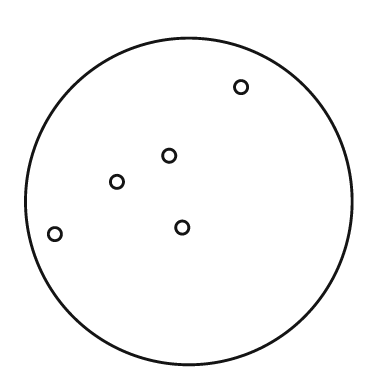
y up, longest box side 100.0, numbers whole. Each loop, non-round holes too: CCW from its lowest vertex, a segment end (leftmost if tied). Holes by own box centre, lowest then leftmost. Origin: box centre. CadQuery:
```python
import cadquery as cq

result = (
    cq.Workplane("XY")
    .moveTo(0.0, 0.0)
    .circle(50.0)
    .moveTo(-41.0, -10.0)
    .circle(2.0)
    .moveTo(-2.0, -8.0)
    .circle(2.0)
    .moveTo(-22.0, 6.0)
    .circle(2.0)
    .moveTo(-6.0, 14.0)
    .circle(2.0)
    .moveTo(16.0, 35.0)
    .circle(2.0)
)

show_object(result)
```